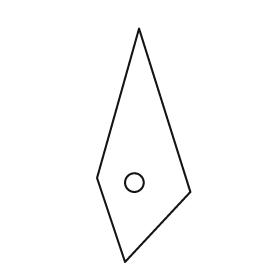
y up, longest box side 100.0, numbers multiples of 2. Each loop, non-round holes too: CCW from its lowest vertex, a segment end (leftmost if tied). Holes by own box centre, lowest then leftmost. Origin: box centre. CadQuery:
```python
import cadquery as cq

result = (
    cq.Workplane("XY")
    .moveTo(-8.0, -50.0)
    .lineTo(20.0, -20.0)
    .lineTo(-2.0, 50.0)
    .lineTo(-20.0, -14.0)
    .close()
    .moveTo(-4.0, -16.0)
    .circle(4.0)
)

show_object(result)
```